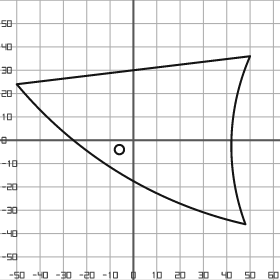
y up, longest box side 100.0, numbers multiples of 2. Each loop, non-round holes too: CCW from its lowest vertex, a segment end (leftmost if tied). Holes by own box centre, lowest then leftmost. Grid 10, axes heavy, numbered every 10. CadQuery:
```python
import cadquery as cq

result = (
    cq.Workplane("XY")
    .moveTo(48.0, -36.0)
    .threePointArc((42.0, 0.0), (50.0, 36.0))
    .lineTo(-50.0, 24.0)
    .threePointArc((-6.0, -14.0), (48.0, -36.0))
    .close()
    .moveTo(-6.0, -4.0)
    .circle(2.0)
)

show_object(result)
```